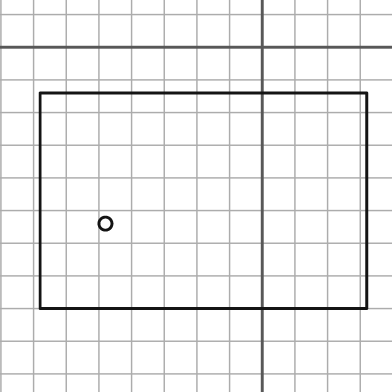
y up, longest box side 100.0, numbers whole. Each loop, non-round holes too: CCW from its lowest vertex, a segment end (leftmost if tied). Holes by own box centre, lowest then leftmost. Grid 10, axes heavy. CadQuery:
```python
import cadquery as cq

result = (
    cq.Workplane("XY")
    .moveTo(-68.0, -80.0)
    .lineTo(32.0, -80.0)
    .lineTo(32.0, -14.0)
    .lineTo(-68.0, -14.0)
    .close()
    .moveTo(-48.0, -54.0)
    .circle(2.0)
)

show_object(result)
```